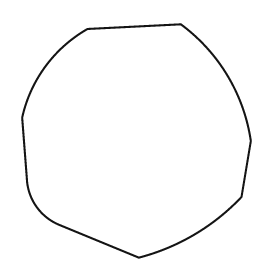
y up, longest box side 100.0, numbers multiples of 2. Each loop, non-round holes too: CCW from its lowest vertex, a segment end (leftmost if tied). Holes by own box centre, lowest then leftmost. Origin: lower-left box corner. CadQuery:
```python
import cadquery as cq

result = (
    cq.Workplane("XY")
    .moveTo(50.0, 0.0)
    .threePointArc((74.0, 10.0), (94.0, 26.0))
    .lineTo(98.0, 50.0)
    .threePointArc((88.0, 78.0), (68.0, 100.0))
    .lineTo(28.0, 98.0)
    .threePointArc((10.0, 82.0), (0.0, 60.0))
    .lineTo(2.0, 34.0)
    .threePointArc((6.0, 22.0), (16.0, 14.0))
    .close()
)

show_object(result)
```